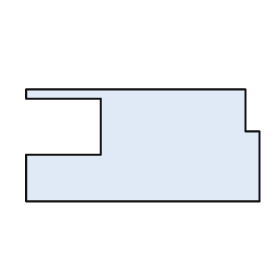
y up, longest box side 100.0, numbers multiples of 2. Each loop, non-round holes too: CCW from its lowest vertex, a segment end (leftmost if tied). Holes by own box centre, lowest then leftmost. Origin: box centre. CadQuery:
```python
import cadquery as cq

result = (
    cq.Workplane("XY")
    .moveTo(-50.0, -24.0)
    .lineTo(50.0, -24.0)
    .lineTo(50.0, 6.0)
    .lineTo(44.0, 6.0)
    .lineTo(44.0, 24.0)
    .lineTo(-50.0, 24.0)
    .lineTo(-50.0, 20.0)
    .lineTo(-18.0, 20.0)
    .lineTo(-18.0, -4.0)
    .lineTo(-50.0, -4.0)
    .close()
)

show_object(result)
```